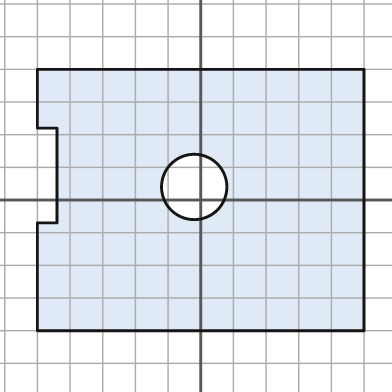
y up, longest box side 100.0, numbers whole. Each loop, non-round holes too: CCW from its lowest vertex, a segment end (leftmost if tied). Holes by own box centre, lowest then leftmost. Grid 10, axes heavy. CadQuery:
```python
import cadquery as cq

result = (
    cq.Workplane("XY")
    .moveTo(-50.0, -40.0)
    .lineTo(50.0, -40.0)
    .lineTo(50.0, 40.0)
    .lineTo(-50.0, 40.0)
    .lineTo(-50.0, 22.0)
    .lineTo(-44.0, 22.0)
    .lineTo(-44.0, -7.0)
    .lineTo(-50.0, -7.0)
    .close()
    .moveTo(-2.0, 4.0)
    .circle(10.0)
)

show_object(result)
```